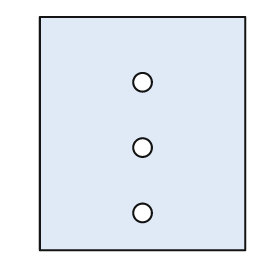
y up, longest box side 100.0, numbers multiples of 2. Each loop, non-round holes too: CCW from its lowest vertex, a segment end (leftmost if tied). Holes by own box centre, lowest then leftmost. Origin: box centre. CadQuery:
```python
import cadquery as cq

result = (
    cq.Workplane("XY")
    .moveTo(-44.0, -50.0)
    .lineTo(44.0, -50.0)
    .lineTo(44.0, 50.0)
    .lineTo(-44.0, 50.0)
    .close()
    .moveTo(0.0, -34.0)
    .circle(4.0)
    .moveTo(0.0, -6.0)
    .circle(4.0)
    .moveTo(0.0, 22.0)
    .circle(4.0)
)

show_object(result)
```